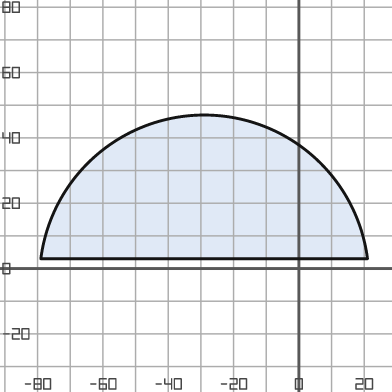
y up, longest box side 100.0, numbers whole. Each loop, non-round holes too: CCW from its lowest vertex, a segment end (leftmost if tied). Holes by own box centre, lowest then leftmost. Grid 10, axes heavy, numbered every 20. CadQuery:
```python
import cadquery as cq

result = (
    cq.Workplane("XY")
    .moveTo(-79.0, 3.0)
    .lineTo(21.0, 3.0)
    .threePointArc((-29.0, 47.0), (-79.0, 3.0))
    .close()
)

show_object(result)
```